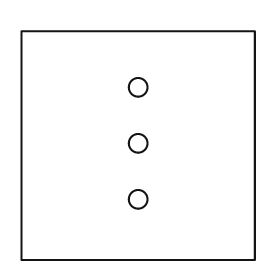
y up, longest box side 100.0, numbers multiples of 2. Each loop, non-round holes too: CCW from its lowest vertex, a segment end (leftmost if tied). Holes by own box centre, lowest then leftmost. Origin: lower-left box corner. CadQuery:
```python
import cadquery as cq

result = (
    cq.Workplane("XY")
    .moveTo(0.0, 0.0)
    .lineTo(100.0, 0.0)
    .lineTo(100.0, 98.0)
    .lineTo(0.0, 98.0)
    .close()
    .moveTo(50.0, 26.0)
    .circle(4.0)
    .moveTo(50.0, 50.0)
    .circle(4.0)
    .moveTo(50.0, 74.0)
    .circle(4.0)
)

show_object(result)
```